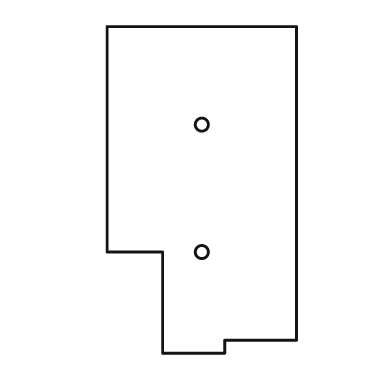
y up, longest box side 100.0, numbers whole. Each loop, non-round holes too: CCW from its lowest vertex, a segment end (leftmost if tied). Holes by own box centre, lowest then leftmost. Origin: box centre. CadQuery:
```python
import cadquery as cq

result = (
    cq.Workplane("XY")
    .moveTo(-12.0, -50.0)
    .lineTo(7.0, -50.0)
    .lineTo(7.0, -46.0)
    .lineTo(29.0, -46.0)
    .lineTo(29.0, 50.0)
    .lineTo(-29.0, 50.0)
    .lineTo(-29.0, -19.0)
    .lineTo(-12.0, -19.0)
    .close()
    .moveTo(0.0, -19.0)
    .circle(2.0)
    .moveTo(0.0, 20.0)
    .circle(2.0)
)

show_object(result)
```